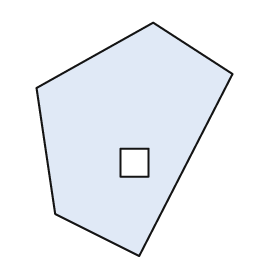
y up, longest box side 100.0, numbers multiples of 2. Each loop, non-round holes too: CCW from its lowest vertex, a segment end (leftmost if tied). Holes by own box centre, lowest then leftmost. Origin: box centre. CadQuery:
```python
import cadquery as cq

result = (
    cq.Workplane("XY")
    .moveTo(2.0, -50.0)
    .lineTo(42.0, 28.0)
    .lineTo(8.0, 50.0)
    .lineTo(-42.0, 22.0)
    .lineTo(-34.0, -32.0)
    .close()
    .moveTo(-6.0, -16.0)
    .lineTo(6.0, -16.0)
    .lineTo(6.0, -4.0)
    .lineTo(-6.0, -4.0)
    .close()
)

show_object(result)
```